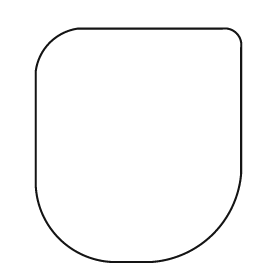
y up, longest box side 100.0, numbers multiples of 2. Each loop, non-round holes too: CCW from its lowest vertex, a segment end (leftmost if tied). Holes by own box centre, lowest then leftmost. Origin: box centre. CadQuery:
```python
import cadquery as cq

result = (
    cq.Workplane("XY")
    .moveTo(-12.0, -50.0)
    .lineTo(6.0, -50.0)
    .threePointArc((32.0, -38.0), (44.0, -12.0))
    .lineTo(44.0, 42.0)
    .threePointArc((42.0, 48.0), (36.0, 50.0))
    .lineTo(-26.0, 50.0)
    .threePointArc((-38.0, 44.0), (-44.0, 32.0))
    .lineTo(-44.0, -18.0)
    .threePointArc((-34.0, -40.0), (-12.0, -50.0))
    .close()
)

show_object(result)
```